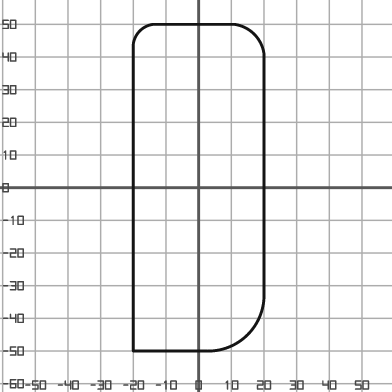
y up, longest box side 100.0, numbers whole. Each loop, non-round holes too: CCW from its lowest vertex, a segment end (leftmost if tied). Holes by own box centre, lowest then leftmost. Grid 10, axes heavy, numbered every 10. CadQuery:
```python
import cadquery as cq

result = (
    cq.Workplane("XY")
    .moveTo(-20.0, -50.0)
    .lineTo(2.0, -50.0)
    .threePointArc((15.0, -45.0), (20.0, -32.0))
    .lineTo(20.0, 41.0)
    .threePointArc((17.0, 47.0), (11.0, 50.0))
    .lineTo(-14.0, 50.0)
    .threePointArc((-18.0, 48.0), (-20.0, 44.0))
    .close()
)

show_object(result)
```